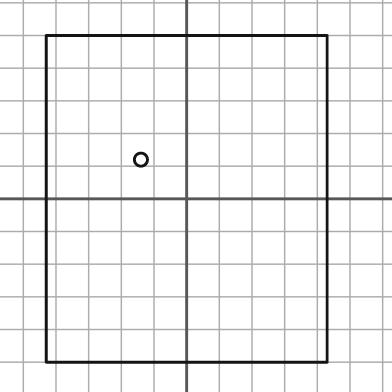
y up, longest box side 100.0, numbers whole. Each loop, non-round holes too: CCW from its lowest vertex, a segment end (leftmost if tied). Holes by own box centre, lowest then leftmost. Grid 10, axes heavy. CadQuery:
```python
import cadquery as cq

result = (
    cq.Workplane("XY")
    .moveTo(-43.0, -50.0)
    .lineTo(43.0, -50.0)
    .lineTo(43.0, 50.0)
    .lineTo(-43.0, 50.0)
    .close()
    .moveTo(-14.0, 12.0)
    .circle(2.0)
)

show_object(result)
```